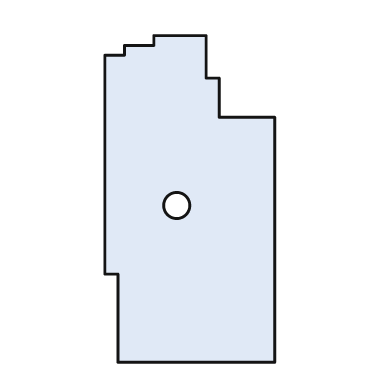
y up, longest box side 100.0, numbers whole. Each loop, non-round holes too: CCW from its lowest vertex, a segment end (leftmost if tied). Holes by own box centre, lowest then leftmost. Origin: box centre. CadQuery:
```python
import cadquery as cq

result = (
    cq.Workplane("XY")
    .moveTo(-22.0, -50.0)
    .lineTo(26.0, -50.0)
    .lineTo(26.0, 25.0)
    .lineTo(9.0, 25.0)
    .lineTo(9.0, 37.0)
    .lineTo(5.0, 37.0)
    .lineTo(5.0, 50.0)
    .lineTo(-11.0, 50.0)
    .lineTo(-11.0, 47.0)
    .lineTo(-20.0, 47.0)
    .lineTo(-20.0, 44.0)
    .lineTo(-26.0, 44.0)
    .lineTo(-26.0, -23.0)
    .lineTo(-22.0, -23.0)
    .close()
    .moveTo(-4.0, -2.0)
    .circle(4.0)
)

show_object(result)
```